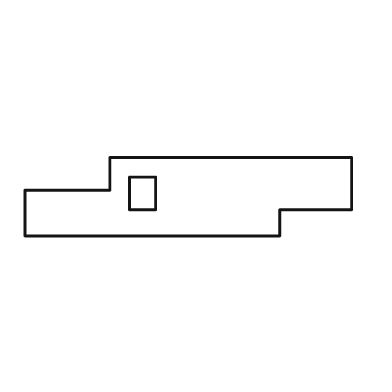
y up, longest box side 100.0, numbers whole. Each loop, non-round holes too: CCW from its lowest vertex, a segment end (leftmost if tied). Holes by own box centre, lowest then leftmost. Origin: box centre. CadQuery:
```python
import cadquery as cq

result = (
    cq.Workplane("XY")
    .moveTo(-50.0, -12.0)
    .lineTo(28.0, -12.0)
    .lineTo(28.0, -4.0)
    .lineTo(50.0, -4.0)
    .lineTo(50.0, 12.0)
    .lineTo(-24.0, 12.0)
    .lineTo(-24.0, 2.0)
    .lineTo(-50.0, 2.0)
    .close()
    .moveTo(-18.0, -4.0)
    .lineTo(-10.0, -4.0)
    .lineTo(-10.0, 6.0)
    .lineTo(-18.0, 6.0)
    .close()
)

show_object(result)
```